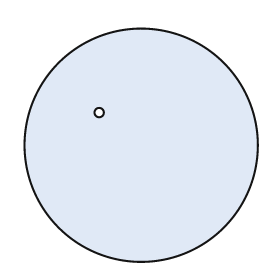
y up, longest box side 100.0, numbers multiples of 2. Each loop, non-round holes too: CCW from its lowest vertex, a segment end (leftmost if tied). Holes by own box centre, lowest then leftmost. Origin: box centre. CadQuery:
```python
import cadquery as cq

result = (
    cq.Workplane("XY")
    .moveTo(0.0, 0.0)
    .circle(50.0)
    .moveTo(-18.0, 14.0)
    .circle(2.0)
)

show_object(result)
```